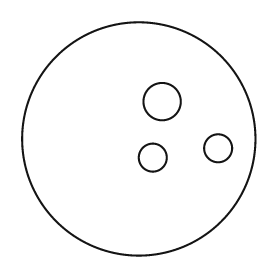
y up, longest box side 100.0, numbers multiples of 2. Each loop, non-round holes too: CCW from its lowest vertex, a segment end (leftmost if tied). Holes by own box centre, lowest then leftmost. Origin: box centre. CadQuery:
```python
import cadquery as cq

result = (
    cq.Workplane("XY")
    .moveTo(0.0, 0.0)
    .circle(50.0)
    .moveTo(6.0, -8.0)
    .circle(6.0)
    .moveTo(34.0, -4.0)
    .circle(6.0)
    .moveTo(10.0, 16.0)
    .circle(8.0)
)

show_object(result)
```